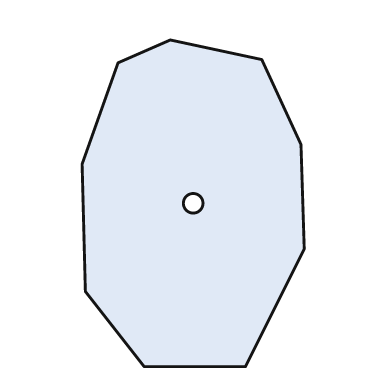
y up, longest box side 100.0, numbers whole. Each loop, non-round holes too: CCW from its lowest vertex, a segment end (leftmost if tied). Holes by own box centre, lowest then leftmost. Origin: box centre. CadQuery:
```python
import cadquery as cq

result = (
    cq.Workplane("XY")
    .moveTo(-15.0, -50.0)
    .lineTo(16.0, -50.0)
    .lineTo(34.0, -14.0)
    .lineTo(33.0, 18.0)
    .lineTo(21.0, 44.0)
    .lineTo(-7.0, 50.0)
    .lineTo(-23.0, 43.0)
    .lineTo(-34.0, 12.0)
    .lineTo(-33.0, -27.0)
    .close()
    .moveTo(0.0, 0.0)
    .circle(3.0)
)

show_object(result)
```